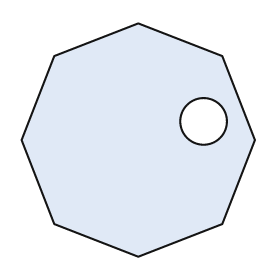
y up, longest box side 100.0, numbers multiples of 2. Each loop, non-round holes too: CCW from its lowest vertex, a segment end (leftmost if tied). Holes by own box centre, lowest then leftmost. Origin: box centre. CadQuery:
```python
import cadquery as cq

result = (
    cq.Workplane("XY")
    .moveTo(0.0, -50.0)
    .lineTo(36.0, -36.0)
    .lineTo(50.0, 0.0)
    .lineTo(36.0, 36.0)
    .lineTo(0.0, 50.0)
    .lineTo(-36.0, 36.0)
    .lineTo(-50.0, 0.0)
    .lineTo(-36.0, -36.0)
    .close()
    .moveTo(28.0, 8.0)
    .circle(10.0)
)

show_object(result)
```